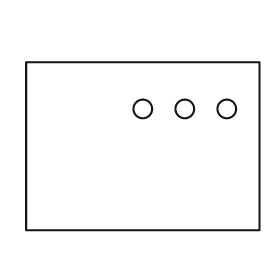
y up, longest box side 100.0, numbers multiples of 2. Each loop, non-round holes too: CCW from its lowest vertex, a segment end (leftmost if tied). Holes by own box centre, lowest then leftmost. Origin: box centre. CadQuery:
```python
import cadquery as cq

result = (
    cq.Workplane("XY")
    .moveTo(-50.0, -36.0)
    .lineTo(50.0, -36.0)
    .lineTo(50.0, 36.0)
    .lineTo(-50.0, 36.0)
    .close()
    .moveTo(0.0, 16.0)
    .circle(4.0)
    .moveTo(18.0, 16.0)
    .circle(4.0)
    .moveTo(36.0, 16.0)
    .circle(4.0)
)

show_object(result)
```